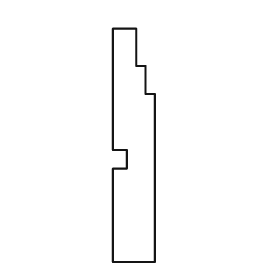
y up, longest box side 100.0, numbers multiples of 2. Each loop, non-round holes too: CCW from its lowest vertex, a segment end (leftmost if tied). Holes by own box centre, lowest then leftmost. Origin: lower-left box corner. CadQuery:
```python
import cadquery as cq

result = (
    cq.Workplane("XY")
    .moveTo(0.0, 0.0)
    .lineTo(18.0, 0.0)
    .lineTo(18.0, 72.0)
    .lineTo(14.0, 72.0)
    .lineTo(14.0, 84.0)
    .lineTo(10.0, 84.0)
    .lineTo(10.0, 100.0)
    .lineTo(0.0, 100.0)
    .lineTo(0.0, 48.0)
    .lineTo(6.0, 48.0)
    .lineTo(6.0, 40.0)
    .lineTo(0.0, 40.0)
    .close()
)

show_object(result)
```